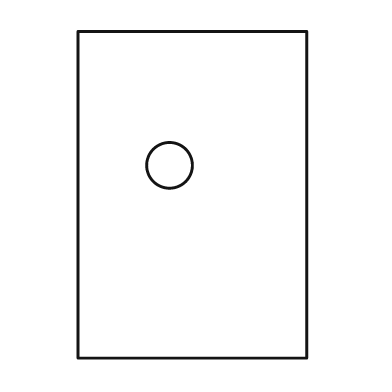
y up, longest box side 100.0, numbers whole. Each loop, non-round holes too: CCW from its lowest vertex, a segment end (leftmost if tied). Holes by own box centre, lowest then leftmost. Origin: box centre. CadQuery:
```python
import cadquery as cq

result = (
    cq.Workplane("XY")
    .moveTo(-35.0, -50.0)
    .lineTo(35.0, -50.0)
    .lineTo(35.0, 50.0)
    .lineTo(-35.0, 50.0)
    .close()
    .moveTo(-7.0, 9.0)
    .circle(7.0)
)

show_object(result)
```